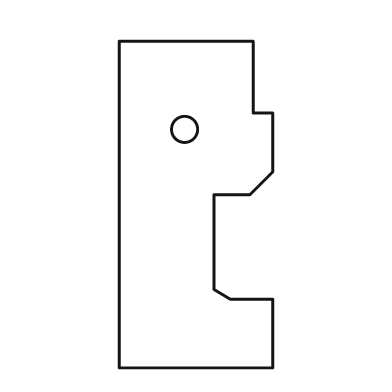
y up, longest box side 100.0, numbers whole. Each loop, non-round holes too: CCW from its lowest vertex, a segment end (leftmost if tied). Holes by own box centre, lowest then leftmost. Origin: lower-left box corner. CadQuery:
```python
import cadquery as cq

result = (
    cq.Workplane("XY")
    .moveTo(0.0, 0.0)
    .lineTo(47.0, 0.0)
    .lineTo(47.0, 21.0)
    .lineTo(34.0, 21.0)
    .lineTo(29.0, 24.0)
    .lineTo(29.0, 53.0)
    .lineTo(40.0, 53.0)
    .lineTo(47.0, 60.0)
    .lineTo(47.0, 78.0)
    .lineTo(41.0, 78.0)
    .lineTo(41.0, 100.0)
    .lineTo(0.0, 100.0)
    .close()
    .moveTo(20.0, 73.0)
    .circle(4.0)
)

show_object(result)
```